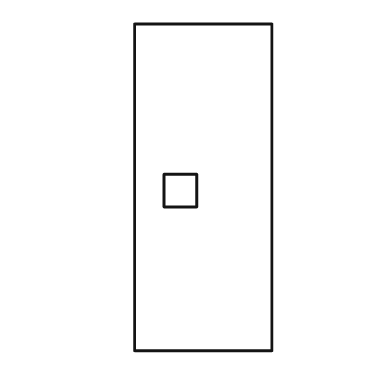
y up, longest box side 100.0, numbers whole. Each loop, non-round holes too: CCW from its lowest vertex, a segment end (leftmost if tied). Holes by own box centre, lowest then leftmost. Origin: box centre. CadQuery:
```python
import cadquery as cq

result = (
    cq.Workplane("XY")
    .moveTo(-21.0, -50.0)
    .lineTo(21.0, -50.0)
    .lineTo(21.0, 50.0)
    .lineTo(-21.0, 50.0)
    .close()
    .moveTo(-12.0, -6.0)
    .lineTo(-2.0, -6.0)
    .lineTo(-2.0, 4.0)
    .lineTo(-12.0, 4.0)
    .close()
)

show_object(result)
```